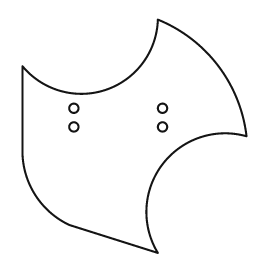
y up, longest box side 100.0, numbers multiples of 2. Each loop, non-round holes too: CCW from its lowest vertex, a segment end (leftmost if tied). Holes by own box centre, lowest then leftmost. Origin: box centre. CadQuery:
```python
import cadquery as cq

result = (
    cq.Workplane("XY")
    .moveTo(10.0, -50.0)
    .threePointArc((12.0, -12.0), (48.0, 0.0))
    .threePointArc((36.0, 30.0), (10.0, 50.0))
    .threePointArc((-12.0, 20.0), (-48.0, 30.0))
    .lineTo(-48.0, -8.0)
    .threePointArc((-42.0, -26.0), (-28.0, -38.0))
    .close()
    .moveTo(-26.0, 4.0)
    .circle(2.0)
    .moveTo(12.0, 4.0)
    .circle(2.0)
    .moveTo(-26.0, 12.0)
    .circle(2.0)
    .moveTo(12.0, 12.0)
    .circle(2.0)
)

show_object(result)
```